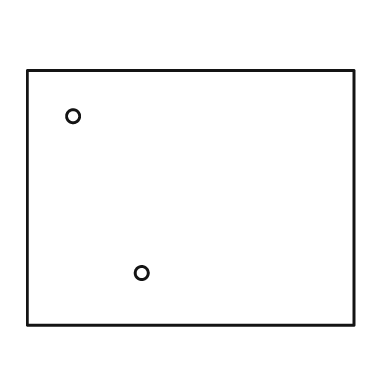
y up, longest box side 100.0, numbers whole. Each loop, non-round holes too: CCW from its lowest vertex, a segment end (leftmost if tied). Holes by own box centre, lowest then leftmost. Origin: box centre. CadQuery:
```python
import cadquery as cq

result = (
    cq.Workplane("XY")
    .moveTo(-50.0, -39.0)
    .lineTo(50.0, -39.0)
    .lineTo(50.0, 39.0)
    .lineTo(-50.0, 39.0)
    .close()
    .moveTo(-15.0, -23.0)
    .circle(2.0)
    .moveTo(-36.0, 25.0)
    .circle(2.0)
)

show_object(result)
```